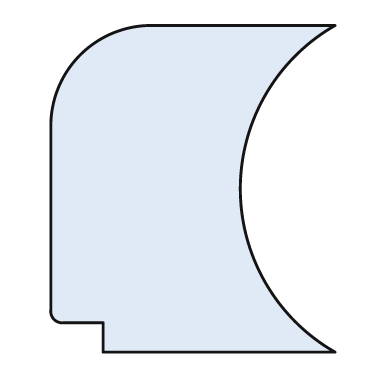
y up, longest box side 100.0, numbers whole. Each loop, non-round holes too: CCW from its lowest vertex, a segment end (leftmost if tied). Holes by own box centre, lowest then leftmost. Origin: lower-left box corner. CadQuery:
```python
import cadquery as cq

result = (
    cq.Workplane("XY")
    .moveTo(16.0, 0.0)
    .lineTo(87.0, 0.0)
    .threePointArc((58.0, 50.0), (87.0, 100.0))
    .lineTo(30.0, 100.0)
    .threePointArc((9.0, 91.0), (0.0, 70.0))
    .lineTo(0.0, 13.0)
    .threePointArc((1.0, 10.0), (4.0, 9.0))
    .lineTo(16.0, 9.0)
    .close()
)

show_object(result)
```